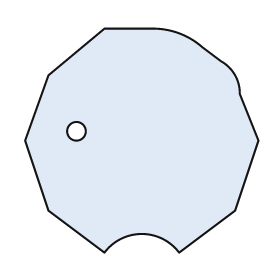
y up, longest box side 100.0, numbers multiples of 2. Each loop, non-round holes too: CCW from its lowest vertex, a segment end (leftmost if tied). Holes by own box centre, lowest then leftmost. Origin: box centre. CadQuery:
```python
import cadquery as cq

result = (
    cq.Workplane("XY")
    .moveTo(-16.0, -48.0)
    .threePointArc((0.0, -40.0), (16.0, -48.0))
    .lineTo(40.0, -30.0)
    .lineTo(50.0, 0.0)
    .lineTo(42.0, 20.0)
    .threePointArc((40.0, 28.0), (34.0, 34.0))
    .lineTo(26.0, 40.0)
    .threePointArc((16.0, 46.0), (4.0, 48.0))
    .lineTo(-16.0, 48.0)
    .lineTo(-40.0, 28.0)
    .lineTo(-50.0, 0.0)
    .lineTo(-40.0, -30.0)
    .close()
    .moveTo(-28.0, 4.0)
    .circle(4.0)
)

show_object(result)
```